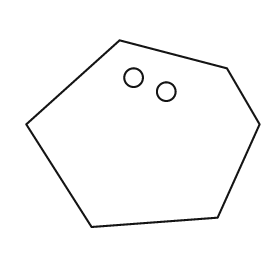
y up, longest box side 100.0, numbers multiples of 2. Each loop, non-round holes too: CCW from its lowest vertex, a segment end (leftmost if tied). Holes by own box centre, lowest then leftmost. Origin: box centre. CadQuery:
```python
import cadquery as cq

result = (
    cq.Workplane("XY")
    .moveTo(-22.0, -40.0)
    .lineTo(32.0, -36.0)
    .lineTo(50.0, 4.0)
    .lineTo(36.0, 28.0)
    .lineTo(-10.0, 40.0)
    .lineTo(-50.0, 4.0)
    .close()
    .moveTo(10.0, 18.0)
    .circle(4.0)
    .moveTo(-4.0, 24.0)
    .circle(4.0)
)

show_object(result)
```